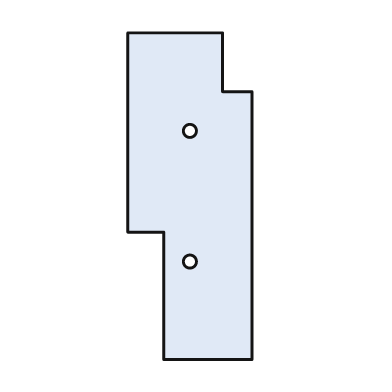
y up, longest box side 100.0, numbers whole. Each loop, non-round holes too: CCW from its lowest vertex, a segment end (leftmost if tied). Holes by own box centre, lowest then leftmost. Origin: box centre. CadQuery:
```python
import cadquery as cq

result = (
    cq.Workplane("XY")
    .moveTo(-8.0, -50.0)
    .lineTo(19.0, -50.0)
    .lineTo(19.0, 32.0)
    .lineTo(10.0, 32.0)
    .lineTo(10.0, 50.0)
    .lineTo(-19.0, 50.0)
    .lineTo(-19.0, -11.0)
    .lineTo(-8.0, -11.0)
    .close()
    .moveTo(0.0, -20.0)
    .circle(2.0)
    .moveTo(0.0, 20.0)
    .circle(2.0)
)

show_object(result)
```